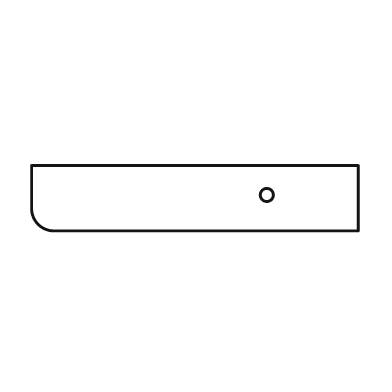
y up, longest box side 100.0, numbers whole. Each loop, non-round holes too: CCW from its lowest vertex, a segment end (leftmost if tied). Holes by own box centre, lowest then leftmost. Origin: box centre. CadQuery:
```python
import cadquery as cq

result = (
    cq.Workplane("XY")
    .moveTo(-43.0, -10.0)
    .lineTo(50.0, -10.0)
    .lineTo(50.0, 10.0)
    .lineTo(-50.0, 10.0)
    .lineTo(-50.0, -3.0)
    .threePointArc((-48.0, -8.0), (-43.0, -10.0))
    .close()
    .moveTo(22.0, 1.0)
    .circle(2.0)
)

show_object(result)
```